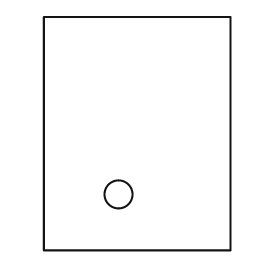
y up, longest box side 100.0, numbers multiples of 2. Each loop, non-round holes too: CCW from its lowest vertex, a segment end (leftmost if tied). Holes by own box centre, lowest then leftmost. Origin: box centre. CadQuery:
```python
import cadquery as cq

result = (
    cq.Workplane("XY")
    .moveTo(-40.0, -50.0)
    .lineTo(40.0, -50.0)
    .lineTo(40.0, 50.0)
    .lineTo(-40.0, 50.0)
    .close()
    .moveTo(-8.0, -26.0)
    .circle(6.0)
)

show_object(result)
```